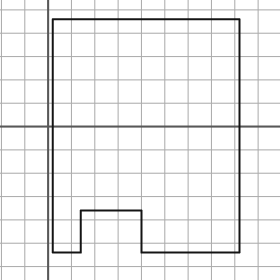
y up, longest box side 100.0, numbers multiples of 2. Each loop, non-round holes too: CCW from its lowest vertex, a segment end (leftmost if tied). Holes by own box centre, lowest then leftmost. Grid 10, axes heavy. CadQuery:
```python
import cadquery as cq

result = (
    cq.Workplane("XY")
    .moveTo(2.0, -54.0)
    .lineTo(14.0, -54.0)
    .lineTo(14.0, -36.0)
    .lineTo(40.0, -36.0)
    .lineTo(40.0, -54.0)
    .lineTo(82.0, -54.0)
    .lineTo(82.0, 46.0)
    .lineTo(2.0, 46.0)
    .close()
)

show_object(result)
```